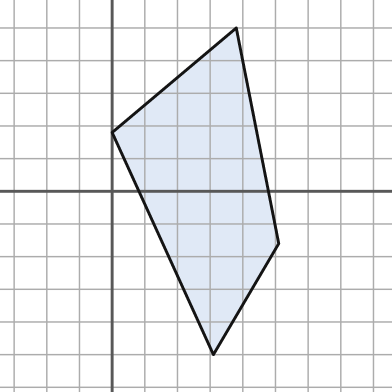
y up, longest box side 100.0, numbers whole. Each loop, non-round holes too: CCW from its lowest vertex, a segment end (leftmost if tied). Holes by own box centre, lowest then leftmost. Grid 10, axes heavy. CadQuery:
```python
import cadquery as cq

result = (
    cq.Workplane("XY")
    .moveTo(31.0, -50.0)
    .lineTo(51.0, -16.0)
    .lineTo(38.0, 50.0)
    .lineTo(0.0, 18.0)
    .close()
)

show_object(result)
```